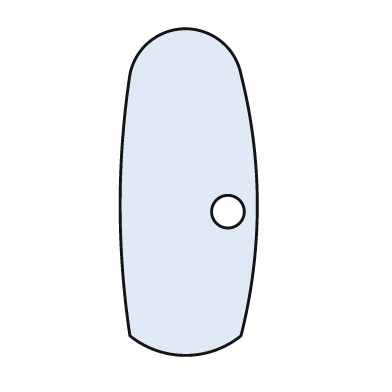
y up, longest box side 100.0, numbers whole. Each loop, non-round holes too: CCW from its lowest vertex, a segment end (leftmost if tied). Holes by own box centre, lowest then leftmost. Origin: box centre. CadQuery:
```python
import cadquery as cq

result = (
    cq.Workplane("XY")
    .moveTo(-18.0, -44.0)
    .threePointArc((-1.0, -50.0), (16.0, -44.0))
    .threePointArc((21.0, -4.0), (16.0, 36.0))
    .threePointArc((-1.0, 50.0), (-18.0, 36.0))
    .threePointArc((-21.0, -4.0), (-18.0, -44.0))
    .close()
    .moveTo(12.0, -6.0)
    .circle(5.0)
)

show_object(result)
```